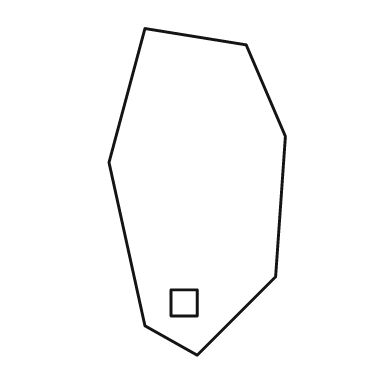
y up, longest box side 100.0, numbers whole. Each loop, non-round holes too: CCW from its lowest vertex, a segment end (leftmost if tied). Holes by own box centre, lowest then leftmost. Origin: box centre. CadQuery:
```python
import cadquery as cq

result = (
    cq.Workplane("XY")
    .moveTo(0.0, -50.0)
    .lineTo(24.0, -26.0)
    .lineTo(27.0, 17.0)
    .lineTo(15.0, 45.0)
    .lineTo(-16.0, 50.0)
    .lineTo(-27.0, 9.0)
    .lineTo(-16.0, -41.0)
    .close()
    .moveTo(-8.0, -38.0)
    .lineTo(0.0, -38.0)
    .lineTo(0.0, -30.0)
    .lineTo(-8.0, -30.0)
    .close()
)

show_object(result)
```